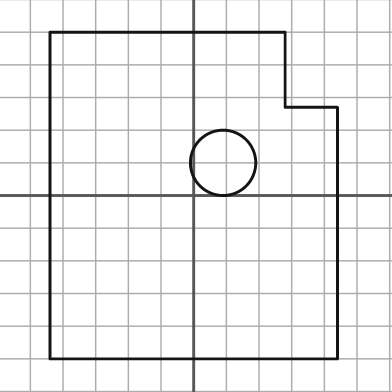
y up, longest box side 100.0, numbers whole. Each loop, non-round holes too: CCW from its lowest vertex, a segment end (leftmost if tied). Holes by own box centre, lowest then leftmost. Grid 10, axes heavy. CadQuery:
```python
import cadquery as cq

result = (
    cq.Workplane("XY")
    .moveTo(-44.0, -50.0)
    .lineTo(44.0, -50.0)
    .lineTo(44.0, 27.0)
    .lineTo(28.0, 27.0)
    .lineTo(28.0, 50.0)
    .lineTo(-44.0, 50.0)
    .close()
    .moveTo(9.0, 10.0)
    .circle(10.0)
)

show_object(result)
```